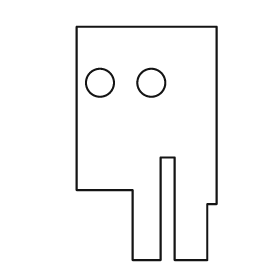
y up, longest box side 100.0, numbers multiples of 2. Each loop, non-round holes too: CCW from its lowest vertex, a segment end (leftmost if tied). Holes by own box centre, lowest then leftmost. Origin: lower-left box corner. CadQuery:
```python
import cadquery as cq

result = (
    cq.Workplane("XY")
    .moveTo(24.0, 0.0)
    .lineTo(36.0, 0.0)
    .lineTo(36.0, 44.0)
    .lineTo(42.0, 44.0)
    .lineTo(42.0, 0.0)
    .lineTo(56.0, 0.0)
    .lineTo(56.0, 24.0)
    .lineTo(60.0, 24.0)
    .lineTo(60.0, 100.0)
    .lineTo(0.0, 100.0)
    .lineTo(0.0, 30.0)
    .lineTo(24.0, 30.0)
    .close()
    .moveTo(10.0, 76.0)
    .circle(6.0)
    .moveTo(32.0, 76.0)
    .circle(6.0)
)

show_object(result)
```